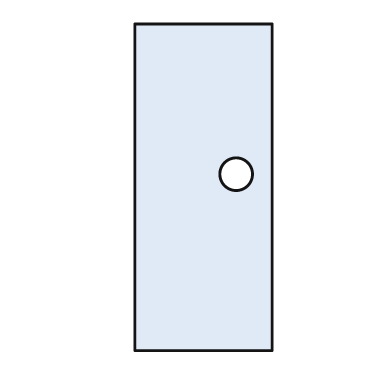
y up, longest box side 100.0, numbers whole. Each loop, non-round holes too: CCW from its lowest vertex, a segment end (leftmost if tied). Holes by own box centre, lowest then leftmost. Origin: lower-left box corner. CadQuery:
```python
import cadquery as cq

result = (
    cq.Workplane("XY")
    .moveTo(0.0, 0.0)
    .lineTo(42.0, 0.0)
    .lineTo(42.0, 100.0)
    .lineTo(0.0, 100.0)
    .close()
    .moveTo(31.0, 54.0)
    .circle(5.0)
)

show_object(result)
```